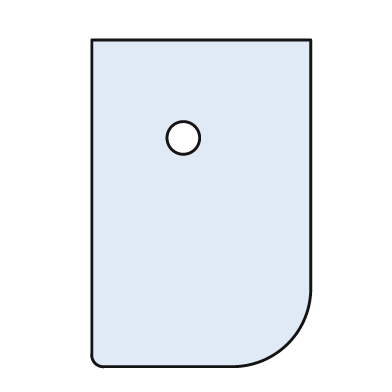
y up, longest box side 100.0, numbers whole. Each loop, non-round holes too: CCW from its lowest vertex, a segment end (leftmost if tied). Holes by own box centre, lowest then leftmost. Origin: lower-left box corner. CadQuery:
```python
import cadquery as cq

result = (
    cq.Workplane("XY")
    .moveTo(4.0, 0.0)
    .lineTo(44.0, 0.0)
    .threePointArc((60.0, 7.0), (67.0, 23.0))
    .lineTo(67.0, 100.0)
    .lineTo(0.0, 100.0)
    .lineTo(0.0, 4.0)
    .threePointArc((1.0, 1.0), (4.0, 0.0))
    .close()
    .moveTo(28.0, 70.0)
    .circle(5.0)
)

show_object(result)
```